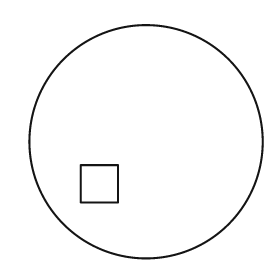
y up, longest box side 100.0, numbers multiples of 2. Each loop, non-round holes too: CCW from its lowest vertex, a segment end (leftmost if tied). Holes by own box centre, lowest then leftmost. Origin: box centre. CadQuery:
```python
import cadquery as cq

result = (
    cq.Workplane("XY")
    .moveTo(0.0, 0.0)
    .circle(50.0)
    .moveTo(-28.0, -26.0)
    .lineTo(-12.0, -26.0)
    .lineTo(-12.0, -10.0)
    .lineTo(-28.0, -10.0)
    .close()
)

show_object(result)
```